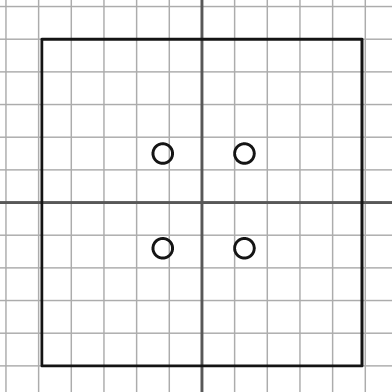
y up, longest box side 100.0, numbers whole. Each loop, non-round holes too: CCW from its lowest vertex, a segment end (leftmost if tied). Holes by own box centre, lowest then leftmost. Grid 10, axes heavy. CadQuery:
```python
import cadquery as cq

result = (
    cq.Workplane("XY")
    .moveTo(-49.0, -50.0)
    .lineTo(49.0, -50.0)
    .lineTo(49.0, 50.0)
    .lineTo(-49.0, 50.0)
    .close()
    .moveTo(-12.0, -14.0)
    .circle(3.0)
    .moveTo(13.0, -14.0)
    .circle(3.0)
    .moveTo(-12.0, 15.0)
    .circle(3.0)
    .moveTo(13.0, 15.0)
    .circle(3.0)
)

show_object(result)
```